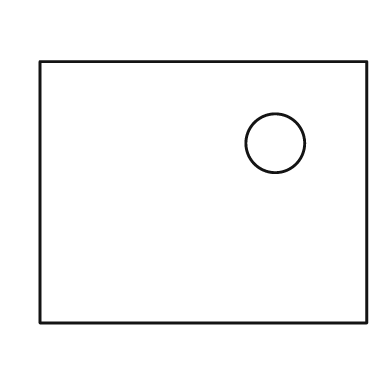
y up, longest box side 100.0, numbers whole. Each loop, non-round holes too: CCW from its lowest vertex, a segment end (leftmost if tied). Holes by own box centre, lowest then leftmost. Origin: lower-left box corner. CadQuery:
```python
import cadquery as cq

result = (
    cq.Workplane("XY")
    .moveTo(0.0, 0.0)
    .lineTo(100.0, 0.0)
    .lineTo(100.0, 80.0)
    .lineTo(0.0, 80.0)
    .close()
    .moveTo(72.0, 55.0)
    .circle(9.0)
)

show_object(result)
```